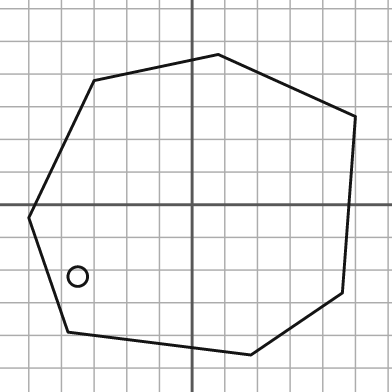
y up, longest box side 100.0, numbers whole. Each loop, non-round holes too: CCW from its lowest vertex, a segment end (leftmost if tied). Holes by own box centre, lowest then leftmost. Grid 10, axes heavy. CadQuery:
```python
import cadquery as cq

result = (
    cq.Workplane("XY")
    .moveTo(18.0, -46.0)
    .lineTo(46.0, -27.0)
    .lineTo(50.0, 27.0)
    .lineTo(8.0, 46.0)
    .lineTo(-30.0, 38.0)
    .lineTo(-50.0, -4.0)
    .lineTo(-38.0, -39.0)
    .close()
    .moveTo(-35.0, -22.0)
    .circle(3.0)
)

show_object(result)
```